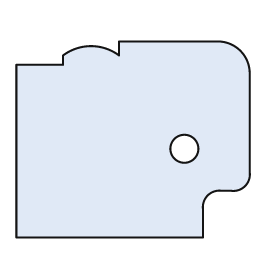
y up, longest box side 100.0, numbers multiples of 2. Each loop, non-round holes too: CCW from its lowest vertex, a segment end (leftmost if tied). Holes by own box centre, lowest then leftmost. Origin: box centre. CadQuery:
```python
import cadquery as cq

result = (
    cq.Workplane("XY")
    .moveTo(-50.0, -42.0)
    .lineTo(30.0, -42.0)
    .lineTo(30.0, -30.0)
    .threePointArc((32.0, -24.0), (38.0, -22.0))
    .lineTo(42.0, -22.0)
    .threePointArc((48.0, -20.0), (50.0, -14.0))
    .lineTo(50.0, 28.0)
    .threePointArc((46.0, 38.0), (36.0, 42.0))
    .lineTo(-6.0, 42.0)
    .lineTo(-6.0, 36.0)
    .threePointArc((-18.0, 40.0), (-30.0, 36.0))
    .lineTo(-30.0, 32.0)
    .lineTo(-50.0, 32.0)
    .close()
    .moveTo(22.0, -4.0)
    .circle(6.0)
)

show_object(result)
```